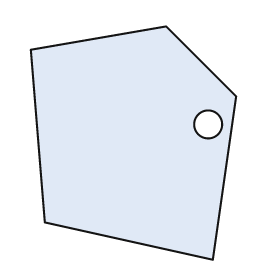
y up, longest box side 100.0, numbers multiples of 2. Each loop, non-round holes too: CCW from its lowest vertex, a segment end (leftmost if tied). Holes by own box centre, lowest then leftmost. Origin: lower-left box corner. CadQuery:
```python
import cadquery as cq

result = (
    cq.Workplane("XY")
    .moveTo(78.0, 0.0)
    .lineTo(88.0, 70.0)
    .lineTo(58.0, 100.0)
    .lineTo(0.0, 90.0)
    .lineTo(6.0, 16.0)
    .close()
    .moveTo(76.0, 58.0)
    .circle(6.0)
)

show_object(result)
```